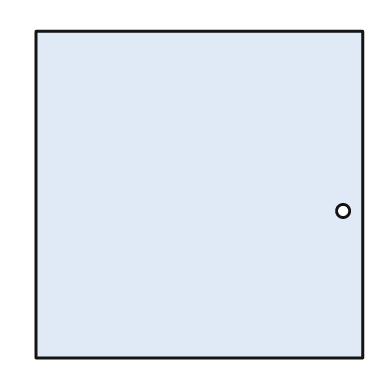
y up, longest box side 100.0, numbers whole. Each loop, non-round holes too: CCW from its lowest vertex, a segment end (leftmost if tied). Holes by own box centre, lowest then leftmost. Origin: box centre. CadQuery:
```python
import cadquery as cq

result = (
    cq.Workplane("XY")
    .moveTo(-50.0, -50.0)
    .lineTo(50.0, -50.0)
    .lineTo(50.0, 50.0)
    .lineTo(-50.0, 50.0)
    .close()
    .moveTo(44.0, -5.0)
    .circle(2.0)
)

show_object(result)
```